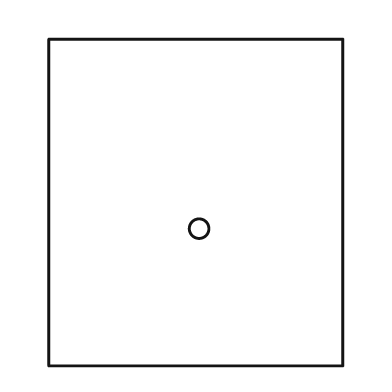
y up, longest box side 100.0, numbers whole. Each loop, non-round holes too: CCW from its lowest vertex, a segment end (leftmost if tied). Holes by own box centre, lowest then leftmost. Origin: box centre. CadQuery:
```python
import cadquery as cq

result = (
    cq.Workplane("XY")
    .moveTo(-45.0, -50.0)
    .lineTo(45.0, -50.0)
    .lineTo(45.0, 50.0)
    .lineTo(-45.0, 50.0)
    .close()
    .moveTo(1.0, -8.0)
    .circle(3.0)
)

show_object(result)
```